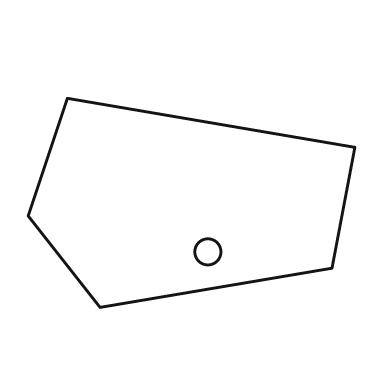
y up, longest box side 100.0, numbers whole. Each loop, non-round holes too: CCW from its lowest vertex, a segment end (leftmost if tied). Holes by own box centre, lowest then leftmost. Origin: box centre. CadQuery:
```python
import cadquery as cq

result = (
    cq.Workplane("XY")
    .moveTo(-28.0, -32.0)
    .lineTo(43.0, -20.0)
    .lineTo(50.0, 17.0)
    .lineTo(-38.0, 32.0)
    .lineTo(-50.0, -4.0)
    .close()
    .moveTo(5.0, -15.0)
    .circle(4.0)
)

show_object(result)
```